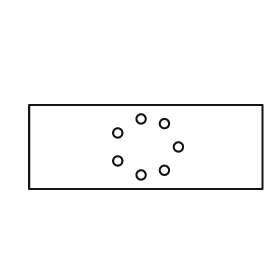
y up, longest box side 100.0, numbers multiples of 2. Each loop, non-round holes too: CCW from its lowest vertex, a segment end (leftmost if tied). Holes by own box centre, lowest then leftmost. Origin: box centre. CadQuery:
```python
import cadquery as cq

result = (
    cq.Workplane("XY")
    .moveTo(-50.0, -18.0)
    .lineTo(50.0, -18.0)
    .lineTo(50.0, 18.0)
    .lineTo(-50.0, 18.0)
    .close()
    .moveTo(-2.0, -12.0)
    .circle(2.0)
    .moveTo(8.0, -10.0)
    .circle(2.0)
    .moveTo(-12.0, -6.0)
    .circle(2.0)
    .moveTo(14.0, 0.0)
    .circle(2.0)
    .moveTo(-12.0, 6.0)
    .circle(2.0)
    .moveTo(8.0, 10.0)
    .circle(2.0)
    .moveTo(-2.0, 12.0)
    .circle(2.0)
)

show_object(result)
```